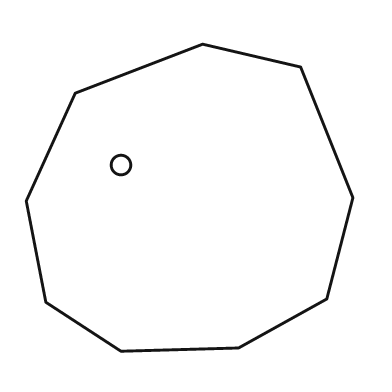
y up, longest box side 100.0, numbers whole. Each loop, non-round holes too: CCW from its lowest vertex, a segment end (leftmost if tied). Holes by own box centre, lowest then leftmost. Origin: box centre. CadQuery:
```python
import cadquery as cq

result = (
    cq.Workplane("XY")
    .moveTo(-21.0, -47.0)
    .lineTo(15.0, -46.0)
    .lineTo(42.0, -31.0)
    .lineTo(50.0, 0.0)
    .lineTo(34.0, 40.0)
    .lineTo(4.0, 47.0)
    .lineTo(-35.0, 32.0)
    .lineTo(-50.0, -1.0)
    .lineTo(-44.0, -32.0)
    .close()
    .moveTo(-21.0, 10.0)
    .circle(3.0)
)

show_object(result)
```